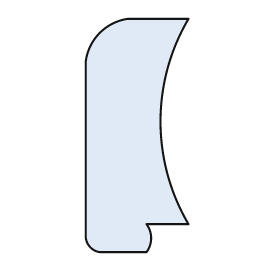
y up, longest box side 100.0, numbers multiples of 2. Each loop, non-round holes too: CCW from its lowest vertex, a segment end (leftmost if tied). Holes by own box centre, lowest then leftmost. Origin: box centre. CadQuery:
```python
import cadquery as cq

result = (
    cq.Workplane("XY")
    .moveTo(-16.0, -50.0)
    .lineTo(4.0, -50.0)
    .threePointArc((6.0, -44.0), (4.0, -38.0))
    .lineTo(22.0, -38.0)
    .threePointArc((10.0, 6.0), (22.0, 50.0))
    .lineTo(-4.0, 50.0)
    .threePointArc((-16.0, 44.0), (-22.0, 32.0))
    .lineTo(-22.0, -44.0)
    .threePointArc((-20.0, -48.0), (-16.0, -50.0))
    .close()
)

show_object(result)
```